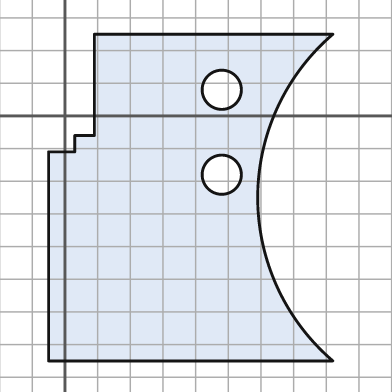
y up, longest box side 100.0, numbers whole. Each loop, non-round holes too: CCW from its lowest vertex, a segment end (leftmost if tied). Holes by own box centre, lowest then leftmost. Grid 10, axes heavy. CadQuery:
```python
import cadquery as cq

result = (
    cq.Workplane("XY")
    .moveTo(-5.0, -75.0)
    .lineTo(82.0, -75.0)
    .threePointArc((59.0, -25.0), (82.0, 25.0))
    .lineTo(9.0, 25.0)
    .lineTo(9.0, -6.0)
    .lineTo(3.0, -6.0)
    .lineTo(3.0, -11.0)
    .lineTo(-5.0, -11.0)
    .close()
    .moveTo(48.0, -18.0)
    .circle(6.0)
    .moveTo(48.0, 8.0)
    .circle(6.0)
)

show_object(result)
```